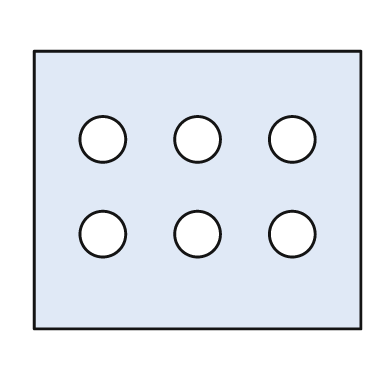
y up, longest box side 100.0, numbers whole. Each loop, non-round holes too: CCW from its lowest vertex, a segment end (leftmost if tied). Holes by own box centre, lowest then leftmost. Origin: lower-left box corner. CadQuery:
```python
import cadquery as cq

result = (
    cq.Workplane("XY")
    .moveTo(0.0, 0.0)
    .lineTo(100.0, 0.0)
    .lineTo(100.0, 85.0)
    .lineTo(0.0, 85.0)
    .close()
    .moveTo(21.0, 29.0)
    .circle(7.0)
    .moveTo(50.0, 29.0)
    .circle(7.0)
    .moveTo(79.0, 29.0)
    .circle(7.0)
    .moveTo(21.0, 58.0)
    .circle(7.0)
    .moveTo(50.0, 58.0)
    .circle(7.0)
    .moveTo(79.0, 58.0)
    .circle(7.0)
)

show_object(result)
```